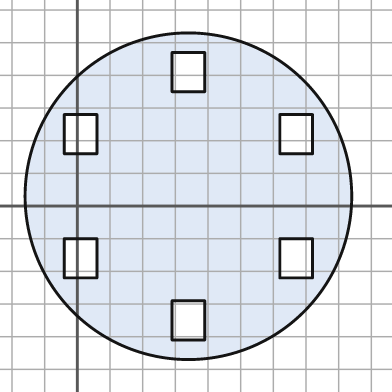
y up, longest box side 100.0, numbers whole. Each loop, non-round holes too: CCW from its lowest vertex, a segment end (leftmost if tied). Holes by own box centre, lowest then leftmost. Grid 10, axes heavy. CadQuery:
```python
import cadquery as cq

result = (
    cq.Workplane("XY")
    .moveTo(34.0, 3.0)
    .circle(50.0)
    .moveTo(29.0, -41.0)
    .lineTo(39.0, -41.0)
    .lineTo(39.0, -29.0)
    .lineTo(29.0, -29.0)
    .close()
    .moveTo(-4.0, -22.0)
    .lineTo(6.0, -22.0)
    .lineTo(6.0, -10.0)
    .lineTo(-4.0, -10.0)
    .close()
    .moveTo(62.0, -22.0)
    .lineTo(72.0, -22.0)
    .lineTo(72.0, -10.0)
    .lineTo(62.0, -10.0)
    .close()
    .moveTo(-4.0, 16.0)
    .lineTo(6.0, 16.0)
    .lineTo(6.0, 28.0)
    .lineTo(-4.0, 28.0)
    .close()
    .moveTo(62.0, 16.0)
    .lineTo(72.0, 16.0)
    .lineTo(72.0, 28.0)
    .lineTo(62.0, 28.0)
    .close()
    .moveTo(29.0, 35.0)
    .lineTo(39.0, 35.0)
    .lineTo(39.0, 47.0)
    .lineTo(29.0, 47.0)
    .close()
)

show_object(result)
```